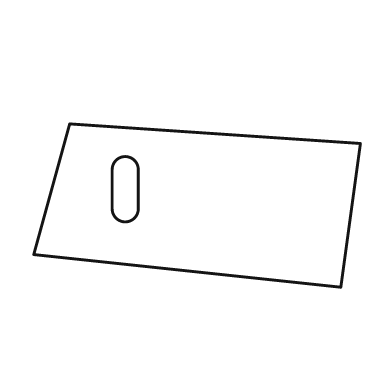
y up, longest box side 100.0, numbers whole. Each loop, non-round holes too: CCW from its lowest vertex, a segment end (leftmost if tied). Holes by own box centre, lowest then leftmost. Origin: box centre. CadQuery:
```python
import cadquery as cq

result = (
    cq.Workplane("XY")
    .moveTo(44.0, -25.0)
    .lineTo(50.0, 19.0)
    .lineTo(-39.0, 25.0)
    .lineTo(-50.0, -15.0)
    .close()
    .moveTo(-26.0, -1.0)
    .threePointArc((-22.0, -5.0), (-18.0, -1.0))
    .lineTo(-18.0, 11.0)
    .threePointArc((-22.0, 15.0), (-26.0, 11.0))
    .close()
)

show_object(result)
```